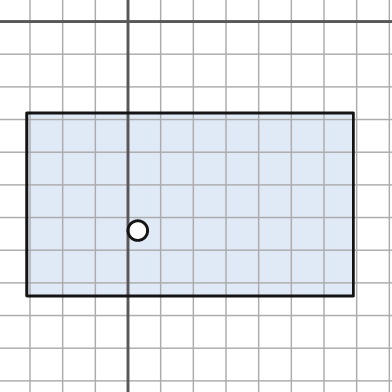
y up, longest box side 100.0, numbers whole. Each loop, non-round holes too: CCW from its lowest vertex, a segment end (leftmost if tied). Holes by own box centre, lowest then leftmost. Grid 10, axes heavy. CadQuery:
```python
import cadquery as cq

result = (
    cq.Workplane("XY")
    .moveTo(-31.0, -84.0)
    .lineTo(69.0, -84.0)
    .lineTo(69.0, -28.0)
    .lineTo(-31.0, -28.0)
    .close()
    .moveTo(3.0, -64.0)
    .circle(3.0)
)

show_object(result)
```